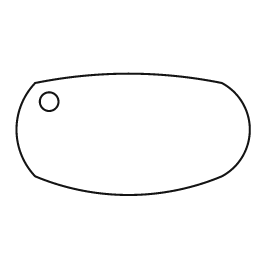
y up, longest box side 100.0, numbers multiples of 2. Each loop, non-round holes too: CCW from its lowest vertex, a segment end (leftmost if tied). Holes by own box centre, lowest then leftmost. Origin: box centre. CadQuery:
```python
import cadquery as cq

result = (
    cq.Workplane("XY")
    .moveTo(-42.0, -18.0)
    .threePointArc((-2.0, -26.0), (38.0, -18.0))
    .threePointArc((50.0, 2.0), (38.0, 22.0))
    .threePointArc((-2.0, 26.0), (-42.0, 22.0))
    .threePointArc((-50.0, 2.0), (-42.0, -18.0))
    .close()
    .moveTo(-36.0, 14.0)
    .circle(4.0)
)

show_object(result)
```